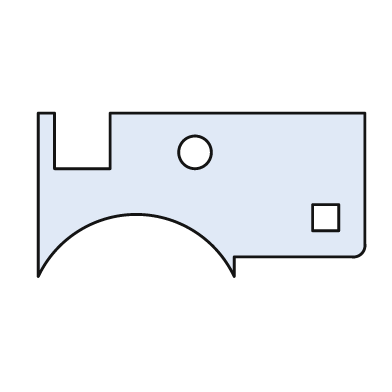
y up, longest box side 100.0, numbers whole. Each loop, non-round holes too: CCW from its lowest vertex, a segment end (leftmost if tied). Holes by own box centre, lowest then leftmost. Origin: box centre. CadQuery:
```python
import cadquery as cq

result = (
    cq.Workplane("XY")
    .moveTo(-50.0, -25.0)
    .threePointArc((-20.0, -6.0), (10.0, -25.0))
    .lineTo(10.0, -19.0)
    .lineTo(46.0, -19.0)
    .threePointArc((49.0, -18.0), (50.0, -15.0))
    .lineTo(50.0, 25.0)
    .lineTo(-28.0, 25.0)
    .lineTo(-28.0, 8.0)
    .lineTo(-45.0, 8.0)
    .lineTo(-45.0, 25.0)
    .lineTo(-50.0, 25.0)
    .close()
    .moveTo(34.0, -11.0)
    .lineTo(42.0, -11.0)
    .lineTo(42.0, -3.0)
    .lineTo(34.0, -3.0)
    .close()
    .moveTo(-2.0, 13.0)
    .circle(5.0)
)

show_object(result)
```